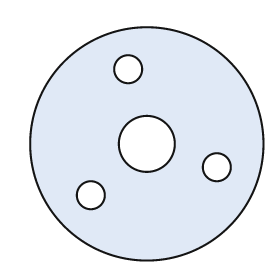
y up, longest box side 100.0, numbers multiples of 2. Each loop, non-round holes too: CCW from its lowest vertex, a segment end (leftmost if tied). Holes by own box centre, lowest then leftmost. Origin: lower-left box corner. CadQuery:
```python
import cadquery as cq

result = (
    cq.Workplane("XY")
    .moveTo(50.0, 50.0)
    .circle(50.0)
    .moveTo(26.0, 28.0)
    .circle(6.0)
    .moveTo(80.0, 40.0)
    .circle(6.0)
    .moveTo(50.0, 50.0)
    .circle(12.0)
    .moveTo(42.0, 82.0)
    .circle(6.0)
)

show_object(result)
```